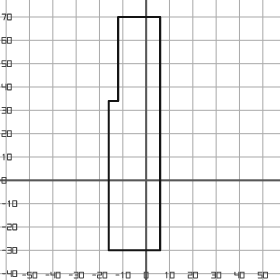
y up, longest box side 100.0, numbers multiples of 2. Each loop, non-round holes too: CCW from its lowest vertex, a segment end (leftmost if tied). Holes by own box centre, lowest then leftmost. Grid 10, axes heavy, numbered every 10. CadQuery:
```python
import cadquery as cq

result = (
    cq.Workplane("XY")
    .moveTo(-16.0, -30.0)
    .lineTo(6.0, -30.0)
    .lineTo(6.0, 70.0)
    .lineTo(-12.0, 70.0)
    .lineTo(-12.0, 34.0)
    .lineTo(-16.0, 34.0)
    .close()
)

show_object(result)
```